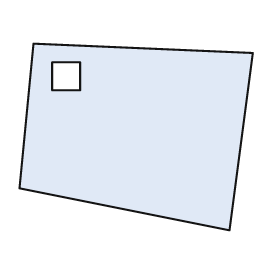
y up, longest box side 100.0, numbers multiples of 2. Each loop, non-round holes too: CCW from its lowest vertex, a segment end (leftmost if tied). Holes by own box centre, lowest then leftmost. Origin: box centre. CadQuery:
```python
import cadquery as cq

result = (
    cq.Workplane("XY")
    .moveTo(40.0, -40.0)
    .lineTo(50.0, 36.0)
    .lineTo(-44.0, 40.0)
    .lineTo(-50.0, -22.0)
    .close()
    .moveTo(-36.0, 20.0)
    .lineTo(-24.0, 20.0)
    .lineTo(-24.0, 32.0)
    .lineTo(-36.0, 32.0)
    .close()
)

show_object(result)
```